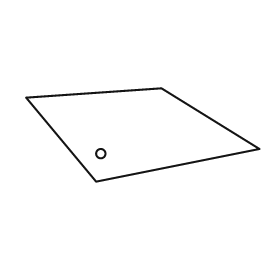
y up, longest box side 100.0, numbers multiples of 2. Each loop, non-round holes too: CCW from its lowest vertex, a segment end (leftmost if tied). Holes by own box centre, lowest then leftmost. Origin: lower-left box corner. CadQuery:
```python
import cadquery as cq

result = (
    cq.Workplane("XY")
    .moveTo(30.0, 0.0)
    .lineTo(100.0, 14.0)
    .lineTo(58.0, 40.0)
    .lineTo(0.0, 36.0)
    .close()
    .moveTo(32.0, 12.0)
    .circle(2.0)
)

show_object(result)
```